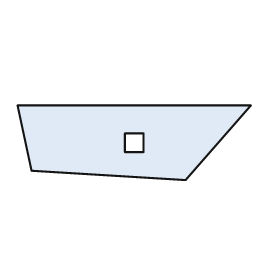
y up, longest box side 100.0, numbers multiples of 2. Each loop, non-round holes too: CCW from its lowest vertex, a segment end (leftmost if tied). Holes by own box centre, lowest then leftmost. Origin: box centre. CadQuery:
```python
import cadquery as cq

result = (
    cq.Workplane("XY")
    .moveTo(22.0, -16.0)
    .lineTo(50.0, 16.0)
    .lineTo(-50.0, 16.0)
    .lineTo(-44.0, -12.0)
    .close()
    .moveTo(-4.0, -4.0)
    .lineTo(4.0, -4.0)
    .lineTo(4.0, 4.0)
    .lineTo(-4.0, 4.0)
    .close()
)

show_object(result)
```